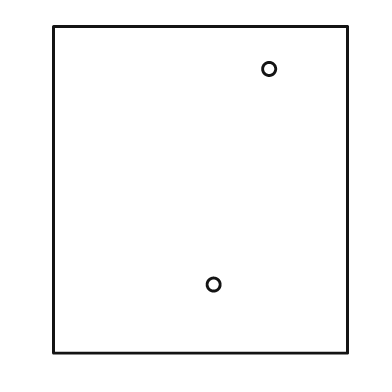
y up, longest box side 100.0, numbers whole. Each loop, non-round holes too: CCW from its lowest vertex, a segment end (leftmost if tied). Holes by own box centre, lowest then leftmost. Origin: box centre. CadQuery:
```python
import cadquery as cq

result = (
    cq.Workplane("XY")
    .moveTo(-45.0, -50.0)
    .lineTo(45.0, -50.0)
    .lineTo(45.0, 50.0)
    .lineTo(-45.0, 50.0)
    .close()
    .moveTo(4.0, -29.0)
    .circle(2.0)
    .moveTo(21.0, 37.0)
    .circle(2.0)
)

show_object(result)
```